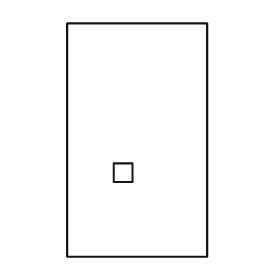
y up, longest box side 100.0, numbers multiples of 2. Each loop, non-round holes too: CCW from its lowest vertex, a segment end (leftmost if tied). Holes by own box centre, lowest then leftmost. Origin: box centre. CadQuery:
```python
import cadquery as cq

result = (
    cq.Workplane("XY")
    .moveTo(-30.0, -50.0)
    .lineTo(30.0, -50.0)
    .lineTo(30.0, 50.0)
    .lineTo(-30.0, 50.0)
    .close()
    .moveTo(-10.0, -18.0)
    .lineTo(-2.0, -18.0)
    .lineTo(-2.0, -10.0)
    .lineTo(-10.0, -10.0)
    .close()
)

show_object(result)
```